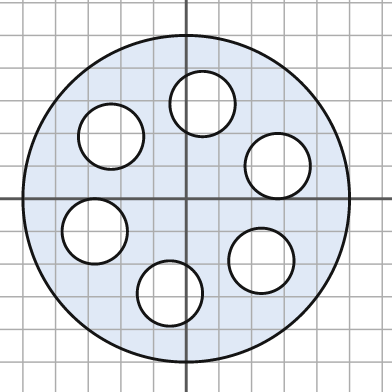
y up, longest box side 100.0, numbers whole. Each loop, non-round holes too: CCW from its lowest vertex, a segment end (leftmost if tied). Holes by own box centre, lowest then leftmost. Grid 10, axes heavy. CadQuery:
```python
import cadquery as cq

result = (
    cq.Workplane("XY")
    .moveTo(0.0, 0.0)
    .circle(50.0)
    .moveTo(-5.0, -29.0)
    .circle(10.0)
    .moveTo(23.0, -19.0)
    .circle(10.0)
    .moveTo(-28.0, -10.0)
    .circle(10.0)
    .moveTo(28.0, 10.0)
    .circle(10.0)
    .moveTo(-23.0, 19.0)
    .circle(10.0)
    .moveTo(5.0, 29.0)
    .circle(10.0)
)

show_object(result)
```